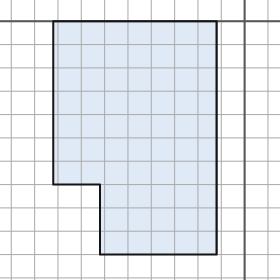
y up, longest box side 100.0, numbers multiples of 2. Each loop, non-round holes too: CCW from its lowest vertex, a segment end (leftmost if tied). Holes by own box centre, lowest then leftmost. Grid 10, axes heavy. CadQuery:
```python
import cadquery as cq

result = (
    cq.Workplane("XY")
    .moveTo(-62.0, -100.0)
    .lineTo(-12.0, -100.0)
    .lineTo(-12.0, 0.0)
    .lineTo(-82.0, 0.0)
    .lineTo(-82.0, -70.0)
    .lineTo(-62.0, -70.0)
    .close()
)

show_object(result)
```